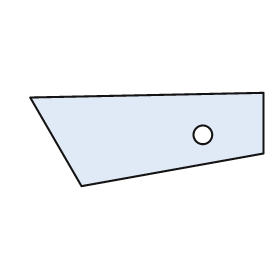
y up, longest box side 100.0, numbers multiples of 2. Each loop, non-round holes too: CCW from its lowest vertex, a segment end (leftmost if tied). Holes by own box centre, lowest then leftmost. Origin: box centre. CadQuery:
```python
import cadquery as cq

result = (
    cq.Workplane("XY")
    .moveTo(-28.0, -20.0)
    .lineTo(50.0, -6.0)
    .lineTo(50.0, 20.0)
    .lineTo(-50.0, 18.0)
    .close()
    .moveTo(24.0, 2.0)
    .circle(4.0)
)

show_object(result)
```